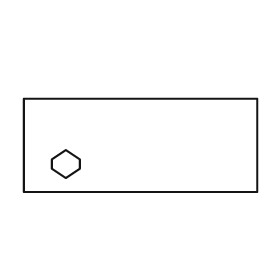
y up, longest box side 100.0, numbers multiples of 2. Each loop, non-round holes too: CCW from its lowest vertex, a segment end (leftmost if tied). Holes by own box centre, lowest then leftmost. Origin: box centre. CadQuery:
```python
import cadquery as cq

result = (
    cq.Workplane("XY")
    .moveTo(-50.0, -20.0)
    .lineTo(50.0, -20.0)
    .lineTo(50.0, 20.0)
    .lineTo(-50.0, 20.0)
    .close()
    .moveTo(-32.0, -14.0)
    .lineTo(-26.0, -10.0)
    .lineTo(-26.0, -6.0)
    .lineTo(-32.0, -2.0)
    .lineTo(-38.0, -6.0)
    .lineTo(-38.0, -10.0)
    .close()
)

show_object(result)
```